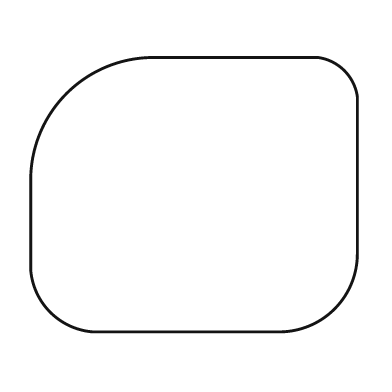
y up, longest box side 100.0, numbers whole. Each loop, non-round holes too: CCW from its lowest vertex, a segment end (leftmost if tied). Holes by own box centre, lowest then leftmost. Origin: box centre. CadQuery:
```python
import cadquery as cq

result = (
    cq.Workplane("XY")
    .moveTo(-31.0, -42.0)
    .lineTo(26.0, -42.0)
    .threePointArc((43.0, -35.0), (50.0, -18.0))
    .lineTo(50.0, 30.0)
    .threePointArc((46.0, 38.0), (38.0, 42.0))
    .lineTo(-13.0, 42.0)
    .threePointArc((-39.0, 31.0), (-50.0, 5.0))
    .lineTo(-50.0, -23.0)
    .threePointArc((-44.0, -36.0), (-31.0, -42.0))
    .close()
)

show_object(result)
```